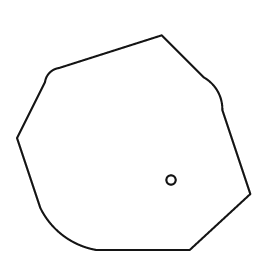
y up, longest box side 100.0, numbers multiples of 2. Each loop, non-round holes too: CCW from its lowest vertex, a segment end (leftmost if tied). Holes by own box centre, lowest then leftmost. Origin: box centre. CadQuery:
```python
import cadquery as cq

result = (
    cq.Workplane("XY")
    .moveTo(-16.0, -46.0)
    .lineTo(24.0, -46.0)
    .lineTo(50.0, -22.0)
    .lineTo(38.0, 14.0)
    .threePointArc((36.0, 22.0), (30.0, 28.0))
    .lineTo(12.0, 46.0)
    .lineTo(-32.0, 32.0)
    .threePointArc((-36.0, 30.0), (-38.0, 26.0))
    .lineTo(-50.0, 2.0)
    .lineTo(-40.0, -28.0)
    .threePointArc((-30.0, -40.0), (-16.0, -46.0))
    .close()
    .moveTo(16.0, -16.0)
    .circle(2.0)
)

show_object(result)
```